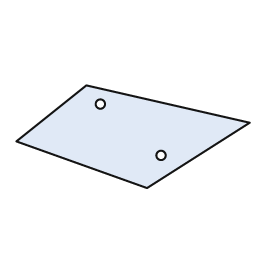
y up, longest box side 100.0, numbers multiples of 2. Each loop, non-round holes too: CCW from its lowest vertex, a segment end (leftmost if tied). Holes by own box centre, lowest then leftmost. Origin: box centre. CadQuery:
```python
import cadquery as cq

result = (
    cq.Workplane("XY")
    .moveTo(6.0, -22.0)
    .lineTo(50.0, 6.0)
    .lineTo(-20.0, 22.0)
    .lineTo(-50.0, -2.0)
    .close()
    .moveTo(12.0, -8.0)
    .circle(2.0)
    .moveTo(-14.0, 14.0)
    .circle(2.0)
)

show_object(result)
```